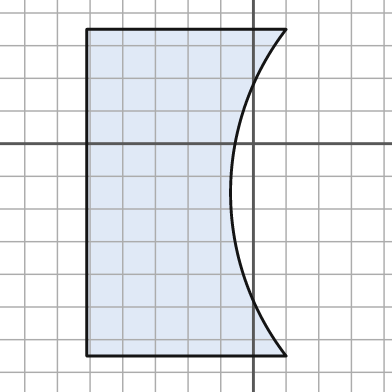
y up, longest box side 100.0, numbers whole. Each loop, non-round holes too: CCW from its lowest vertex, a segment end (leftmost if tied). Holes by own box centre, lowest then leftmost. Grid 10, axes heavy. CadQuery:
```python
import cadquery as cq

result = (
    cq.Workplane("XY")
    .moveTo(-51.0, -65.0)
    .lineTo(10.0, -65.0)
    .threePointArc((-7.0, -15.0), (10.0, 35.0))
    .lineTo(-51.0, 35.0)
    .close()
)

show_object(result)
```